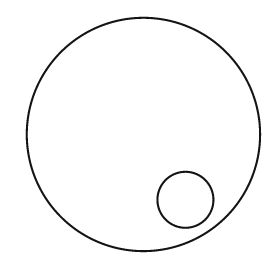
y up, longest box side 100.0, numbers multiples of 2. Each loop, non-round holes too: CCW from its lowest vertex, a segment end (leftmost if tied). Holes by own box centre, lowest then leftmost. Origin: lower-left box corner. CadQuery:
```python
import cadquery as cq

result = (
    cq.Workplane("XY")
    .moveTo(50.0, 50.0)
    .circle(50.0)
    .moveTo(68.0, 22.0)
    .circle(12.0)
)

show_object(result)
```